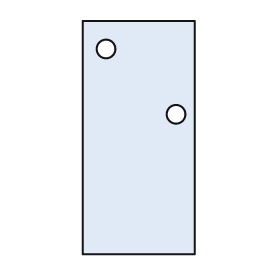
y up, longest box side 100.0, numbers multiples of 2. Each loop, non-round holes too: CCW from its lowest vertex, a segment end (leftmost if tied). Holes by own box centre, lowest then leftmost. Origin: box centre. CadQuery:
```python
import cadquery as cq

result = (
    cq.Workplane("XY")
    .moveTo(-24.0, -50.0)
    .lineTo(24.0, -50.0)
    .lineTo(24.0, 50.0)
    .lineTo(-24.0, 50.0)
    .close()
    .moveTo(16.0, 10.0)
    .circle(4.0)
    .moveTo(-14.0, 38.0)
    .circle(4.0)
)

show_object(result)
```